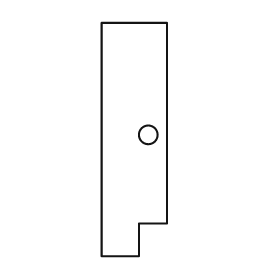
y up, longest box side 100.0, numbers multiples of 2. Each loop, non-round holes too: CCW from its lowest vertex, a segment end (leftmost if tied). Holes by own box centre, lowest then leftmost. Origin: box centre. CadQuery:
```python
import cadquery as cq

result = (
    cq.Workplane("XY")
    .moveTo(-14.0, -50.0)
    .lineTo(2.0, -50.0)
    .lineTo(2.0, -36.0)
    .lineTo(14.0, -36.0)
    .lineTo(14.0, 50.0)
    .lineTo(-14.0, 50.0)
    .close()
    .moveTo(6.0, 2.0)
    .circle(4.0)
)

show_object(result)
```